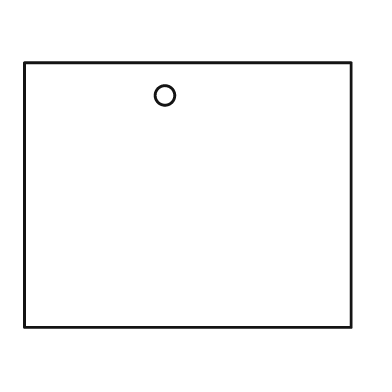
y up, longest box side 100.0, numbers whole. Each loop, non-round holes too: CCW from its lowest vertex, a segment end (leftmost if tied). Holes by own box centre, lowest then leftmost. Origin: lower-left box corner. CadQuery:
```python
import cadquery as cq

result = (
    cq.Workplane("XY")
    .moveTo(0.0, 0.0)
    .lineTo(100.0, 0.0)
    .lineTo(100.0, 81.0)
    .lineTo(0.0, 81.0)
    .close()
    .moveTo(43.0, 71.0)
    .circle(3.0)
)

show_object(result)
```